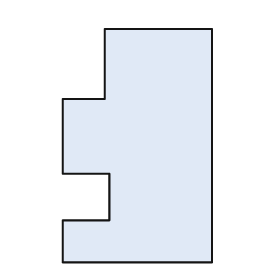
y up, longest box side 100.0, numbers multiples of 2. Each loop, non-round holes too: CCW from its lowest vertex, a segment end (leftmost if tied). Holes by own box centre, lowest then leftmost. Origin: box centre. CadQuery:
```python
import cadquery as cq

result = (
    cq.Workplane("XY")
    .moveTo(-32.0, -50.0)
    .lineTo(32.0, -50.0)
    .lineTo(32.0, 50.0)
    .lineTo(-14.0, 50.0)
    .lineTo(-14.0, 20.0)
    .lineTo(-32.0, 20.0)
    .lineTo(-32.0, -12.0)
    .lineTo(-12.0, -12.0)
    .lineTo(-12.0, -32.0)
    .lineTo(-32.0, -32.0)
    .close()
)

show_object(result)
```